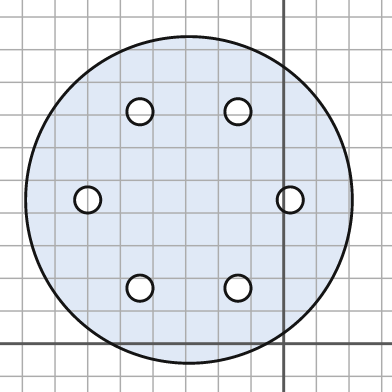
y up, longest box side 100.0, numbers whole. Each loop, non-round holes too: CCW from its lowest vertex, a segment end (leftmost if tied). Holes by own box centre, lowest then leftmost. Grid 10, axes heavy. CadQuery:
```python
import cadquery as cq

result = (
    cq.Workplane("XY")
    .moveTo(-29.0, 44.0)
    .circle(50.0)
    .moveTo(-44.0, 17.0)
    .circle(4.0)
    .moveTo(-14.0, 17.0)
    .circle(4.0)
    .moveTo(-60.0, 44.0)
    .circle(4.0)
    .moveTo(2.0, 44.0)
    .circle(4.0)
    .moveTo(-44.0, 71.0)
    .circle(4.0)
    .moveTo(-14.0, 71.0)
    .circle(4.0)
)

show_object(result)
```